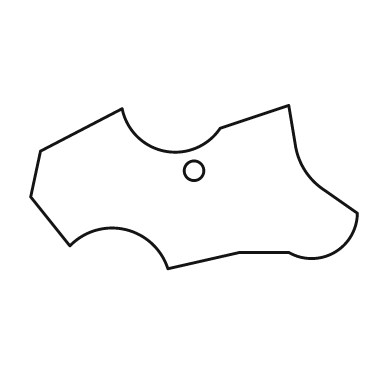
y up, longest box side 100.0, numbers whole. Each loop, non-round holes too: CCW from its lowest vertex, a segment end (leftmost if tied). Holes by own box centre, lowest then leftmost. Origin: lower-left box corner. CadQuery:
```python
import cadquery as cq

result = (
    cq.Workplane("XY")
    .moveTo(42.0, 0.0)
    .lineTo(64.0, 5.0)
    .lineTo(79.0, 5.0)
    .threePointArc((93.0, 5.0), (100.0, 17.0))
    .lineTo(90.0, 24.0)
    .threePointArc((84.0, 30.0), (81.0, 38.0))
    .lineTo(79.0, 50.0)
    .lineTo(58.0, 43.0)
    .threePointArc((41.0, 36.0), (28.0, 49.0))
    .lineTo(3.0, 36.0)
    .lineTo(0.0, 22.0)
    .lineTo(12.0, 7.0)
    .threePointArc((29.0, 12.0), (42.0, 0.0))
    .close()
    .moveTo(50.0, 30.0)
    .circle(3.0)
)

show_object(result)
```